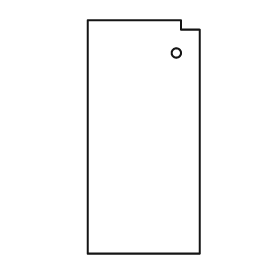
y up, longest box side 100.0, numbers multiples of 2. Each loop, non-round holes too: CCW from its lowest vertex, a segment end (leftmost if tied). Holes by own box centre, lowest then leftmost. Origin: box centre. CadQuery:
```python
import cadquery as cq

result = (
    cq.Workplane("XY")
    .moveTo(-24.0, -50.0)
    .lineTo(24.0, -50.0)
    .lineTo(24.0, 46.0)
    .lineTo(16.0, 46.0)
    .lineTo(16.0, 50.0)
    .lineTo(-24.0, 50.0)
    .close()
    .moveTo(14.0, 36.0)
    .circle(2.0)
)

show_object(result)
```